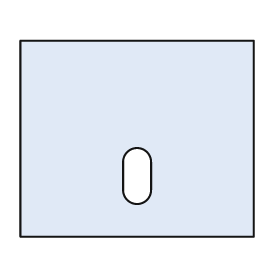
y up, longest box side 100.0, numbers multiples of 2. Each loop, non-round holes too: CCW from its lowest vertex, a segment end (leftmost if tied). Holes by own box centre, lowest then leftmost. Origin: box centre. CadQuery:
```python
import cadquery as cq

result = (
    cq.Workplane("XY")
    .moveTo(-50.0, -42.0)
    .lineTo(50.0, -42.0)
    .lineTo(50.0, 42.0)
    .lineTo(-50.0, 42.0)
    .close()
    .moveTo(-6.0, -22.0)
    .threePointArc((0.0, -28.0), (6.0, -22.0))
    .lineTo(6.0, -10.0)
    .threePointArc((0.0, -4.0), (-6.0, -10.0))
    .close()
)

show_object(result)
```